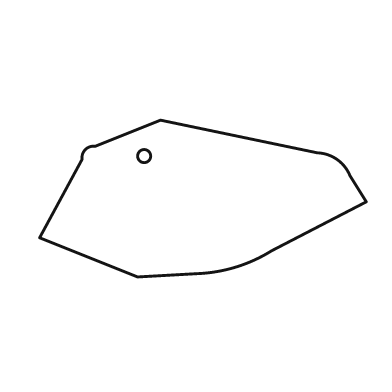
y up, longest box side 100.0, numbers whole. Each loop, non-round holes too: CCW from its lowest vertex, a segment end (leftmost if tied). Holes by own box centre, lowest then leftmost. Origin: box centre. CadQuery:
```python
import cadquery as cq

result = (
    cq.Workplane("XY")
    .moveTo(-20.0, -24.0)
    .lineTo(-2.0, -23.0)
    .threePointArc((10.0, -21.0), (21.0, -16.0))
    .lineTo(50.0, -1.0)
    .lineTo(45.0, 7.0)
    .threePointArc((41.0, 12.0), (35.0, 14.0))
    .lineTo(-13.0, 24.0)
    .lineTo(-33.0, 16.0)
    .threePointArc((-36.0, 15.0), (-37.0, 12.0))
    .lineTo(-50.0, -12.0)
    .close()
    .moveTo(-18.0, 13.0)
    .circle(2.0)
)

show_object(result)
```